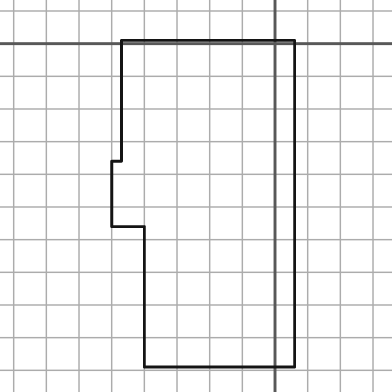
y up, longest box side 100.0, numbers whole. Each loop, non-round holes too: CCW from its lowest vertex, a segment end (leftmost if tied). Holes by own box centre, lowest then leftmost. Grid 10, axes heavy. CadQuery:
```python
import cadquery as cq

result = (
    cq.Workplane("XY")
    .moveTo(-40.0, -99.0)
    .lineTo(6.0, -99.0)
    .lineTo(6.0, 1.0)
    .lineTo(-47.0, 1.0)
    .lineTo(-47.0, -36.0)
    .lineTo(-50.0, -36.0)
    .lineTo(-50.0, -56.0)
    .lineTo(-40.0, -56.0)
    .close()
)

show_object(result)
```